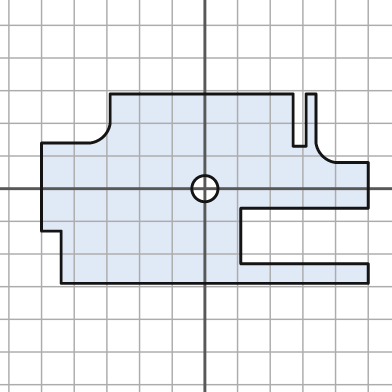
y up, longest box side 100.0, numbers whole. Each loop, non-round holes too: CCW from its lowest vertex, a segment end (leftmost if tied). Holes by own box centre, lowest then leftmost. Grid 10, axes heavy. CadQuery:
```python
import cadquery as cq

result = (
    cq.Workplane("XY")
    .moveTo(-44.0, -29.0)
    .lineTo(50.0, -29.0)
    .lineTo(50.0, -23.0)
    .lineTo(11.0, -23.0)
    .lineTo(11.0, -6.0)
    .lineTo(50.0, -6.0)
    .lineTo(50.0, 8.0)
    .lineTo(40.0, 8.0)
    .threePointArc((36.0, 10.0), (34.0, 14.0))
    .lineTo(34.0, 29.0)
    .lineTo(31.0, 29.0)
    .lineTo(31.0, 13.0)
    .lineTo(27.0, 13.0)
    .lineTo(27.0, 29.0)
    .lineTo(-29.0, 29.0)
    .lineTo(-29.0, 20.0)
    .threePointArc((-31.0, 16.0), (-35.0, 14.0))
    .lineTo(-50.0, 14.0)
    .lineTo(-50.0, -13.0)
    .lineTo(-44.0, -13.0)
    .close()
    .moveTo(0.0, 0.0)
    .circle(4.0)
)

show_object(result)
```